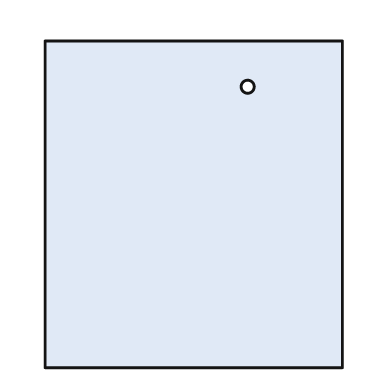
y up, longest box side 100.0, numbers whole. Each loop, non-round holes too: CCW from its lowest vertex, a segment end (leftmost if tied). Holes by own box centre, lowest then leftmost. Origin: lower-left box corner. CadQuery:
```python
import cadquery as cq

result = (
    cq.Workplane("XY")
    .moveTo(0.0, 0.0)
    .lineTo(91.0, 0.0)
    .lineTo(91.0, 100.0)
    .lineTo(0.0, 100.0)
    .close()
    .moveTo(62.0, 86.0)
    .circle(2.0)
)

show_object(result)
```